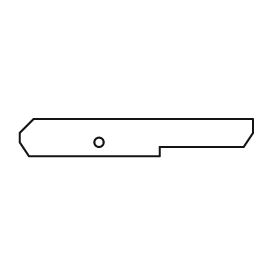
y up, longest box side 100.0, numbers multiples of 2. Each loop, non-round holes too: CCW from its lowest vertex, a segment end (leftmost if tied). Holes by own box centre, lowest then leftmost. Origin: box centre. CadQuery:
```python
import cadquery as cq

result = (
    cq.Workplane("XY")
    .moveTo(-46.0, -8.0)
    .lineTo(10.0, -8.0)
    .lineTo(10.0, -4.0)
    .lineTo(46.0, -4.0)
    .lineTo(50.0, 2.0)
    .lineTo(50.0, 8.0)
    .lineTo(-44.0, 8.0)
    .lineTo(-50.0, 2.0)
    .lineTo(-50.0, -2.0)
    .close()
    .moveTo(-16.0, -2.0)
    .circle(2.0)
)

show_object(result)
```